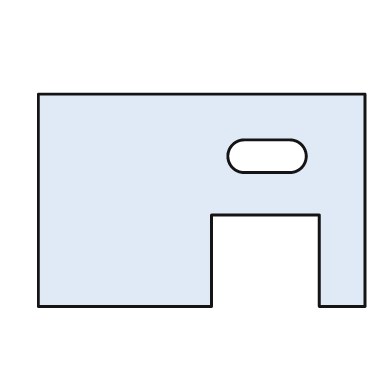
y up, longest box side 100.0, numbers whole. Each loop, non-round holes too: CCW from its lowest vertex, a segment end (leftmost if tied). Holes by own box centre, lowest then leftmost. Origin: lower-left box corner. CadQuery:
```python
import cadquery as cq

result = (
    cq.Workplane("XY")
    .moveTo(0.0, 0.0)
    .lineTo(53.0, 0.0)
    .lineTo(53.0, 28.0)
    .lineTo(86.0, 28.0)
    .lineTo(86.0, 0.0)
    .lineTo(100.0, 0.0)
    .lineTo(100.0, 65.0)
    .lineTo(0.0, 65.0)
    .close()
    .moveTo(63.0, 41.0)
    .lineTo(77.0, 41.0)
    .threePointArc((82.0, 46.0), (77.0, 51.0))
    .lineTo(63.0, 51.0)
    .threePointArc((58.0, 46.0), (63.0, 41.0))
    .close()
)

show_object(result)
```